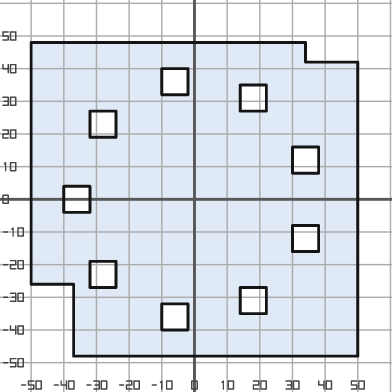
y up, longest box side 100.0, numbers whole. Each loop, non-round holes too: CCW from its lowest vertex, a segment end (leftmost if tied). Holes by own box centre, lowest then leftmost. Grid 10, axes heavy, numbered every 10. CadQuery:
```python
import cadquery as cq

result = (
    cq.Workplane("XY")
    .moveTo(-37.0, -48.0)
    .lineTo(50.0, -48.0)
    .lineTo(50.0, 42.0)
    .lineTo(34.0, 42.0)
    .lineTo(34.0, 48.0)
    .lineTo(-50.0, 48.0)
    .lineTo(-50.0, -26.0)
    .lineTo(-37.0, -26.0)
    .close()
    .moveTo(-10.0, -40.0)
    .lineTo(-2.0, -40.0)
    .lineTo(-2.0, -32.0)
    .lineTo(-10.0, -32.0)
    .close()
    .moveTo(14.0, -35.0)
    .lineTo(22.0, -35.0)
    .lineTo(22.0, -27.0)
    .lineTo(14.0, -27.0)
    .close()
    .moveTo(-32.0, -27.0)
    .lineTo(-24.0, -27.0)
    .lineTo(-24.0, -19.0)
    .lineTo(-32.0, -19.0)
    .close()
    .moveTo(30.0, -16.0)
    .lineTo(38.0, -16.0)
    .lineTo(38.0, -8.0)
    .lineTo(30.0, -8.0)
    .close()
    .moveTo(-40.0, -4.0)
    .lineTo(-32.0, -4.0)
    .lineTo(-32.0, 4.0)
    .lineTo(-40.0, 4.0)
    .close()
    .moveTo(30.0, 8.0)
    .lineTo(38.0, 8.0)
    .lineTo(38.0, 16.0)
    .lineTo(30.0, 16.0)
    .close()
    .moveTo(-32.0, 19.0)
    .lineTo(-24.0, 19.0)
    .lineTo(-24.0, 27.0)
    .lineTo(-32.0, 27.0)
    .close()
    .moveTo(14.0, 27.0)
    .lineTo(22.0, 27.0)
    .lineTo(22.0, 35.0)
    .lineTo(14.0, 35.0)
    .close()
    .moveTo(-10.0, 32.0)
    .lineTo(-2.0, 32.0)
    .lineTo(-2.0, 40.0)
    .lineTo(-10.0, 40.0)
    .close()
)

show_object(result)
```